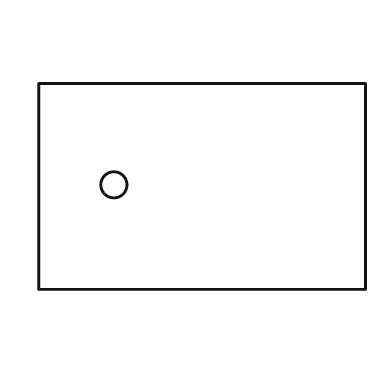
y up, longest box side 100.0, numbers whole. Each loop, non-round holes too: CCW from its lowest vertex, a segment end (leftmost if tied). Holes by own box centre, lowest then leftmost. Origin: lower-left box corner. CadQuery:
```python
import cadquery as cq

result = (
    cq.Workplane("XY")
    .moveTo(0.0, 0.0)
    .lineTo(100.0, 0.0)
    .lineTo(100.0, 63.0)
    .lineTo(0.0, 63.0)
    .close()
    .moveTo(23.0, 32.0)
    .circle(4.0)
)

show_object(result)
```